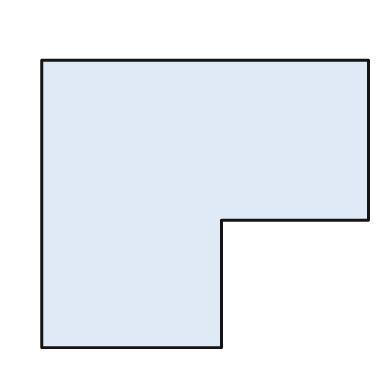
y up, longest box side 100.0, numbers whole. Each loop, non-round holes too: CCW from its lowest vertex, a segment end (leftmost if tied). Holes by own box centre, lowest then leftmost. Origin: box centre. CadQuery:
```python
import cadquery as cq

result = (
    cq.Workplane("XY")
    .moveTo(-50.0, -44.0)
    .lineTo(5.0, -44.0)
    .lineTo(5.0, -5.0)
    .lineTo(50.0, -5.0)
    .lineTo(50.0, 44.0)
    .lineTo(-50.0, 44.0)
    .close()
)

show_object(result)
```